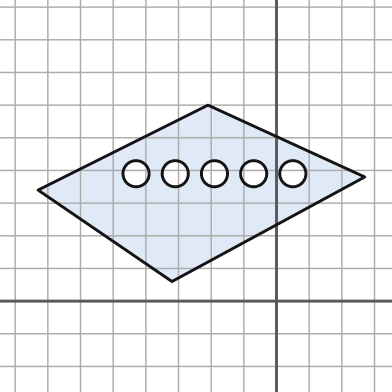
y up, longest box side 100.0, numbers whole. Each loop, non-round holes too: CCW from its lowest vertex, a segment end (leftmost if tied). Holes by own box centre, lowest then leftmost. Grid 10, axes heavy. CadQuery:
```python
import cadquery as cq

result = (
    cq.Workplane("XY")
    .moveTo(-32.0, 6.0)
    .lineTo(27.0, 38.0)
    .lineTo(-21.0, 60.0)
    .lineTo(-73.0, 34.0)
    .close()
    .moveTo(-43.0, 39.0)
    .circle(4.0)
    .moveTo(-31.0, 39.0)
    .circle(4.0)
    .moveTo(-19.0, 39.0)
    .circle(4.0)
    .moveTo(-7.0, 39.0)
    .circle(4.0)
    .moveTo(5.0, 39.0)
    .circle(4.0)
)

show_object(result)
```